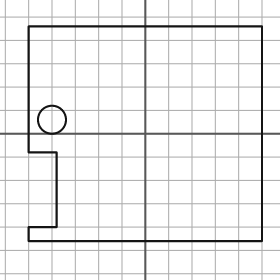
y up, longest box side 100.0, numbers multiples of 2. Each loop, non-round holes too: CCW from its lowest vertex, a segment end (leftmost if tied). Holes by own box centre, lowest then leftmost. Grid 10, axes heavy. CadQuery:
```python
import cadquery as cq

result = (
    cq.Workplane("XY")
    .moveTo(-50.0, -46.0)
    .lineTo(50.0, -46.0)
    .lineTo(50.0, 46.0)
    .lineTo(-50.0, 46.0)
    .lineTo(-50.0, -8.0)
    .lineTo(-38.0, -8.0)
    .lineTo(-38.0, -40.0)
    .lineTo(-50.0, -40.0)
    .close()
    .moveTo(-40.0, 6.0)
    .circle(6.0)
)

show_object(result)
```